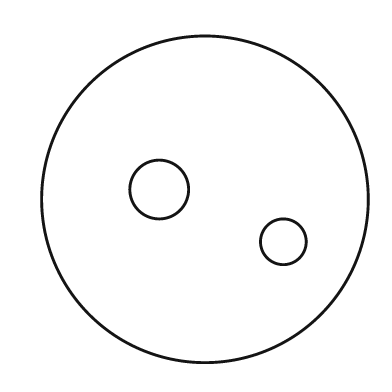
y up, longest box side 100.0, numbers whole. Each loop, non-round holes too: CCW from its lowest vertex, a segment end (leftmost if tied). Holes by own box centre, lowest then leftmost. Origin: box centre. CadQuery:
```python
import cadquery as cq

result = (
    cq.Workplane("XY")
    .moveTo(0.0, 0.0)
    .circle(50.0)
    .moveTo(24.0, -13.0)
    .circle(7.0)
    .moveTo(-14.0, 3.0)
    .circle(9.0)
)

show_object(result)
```